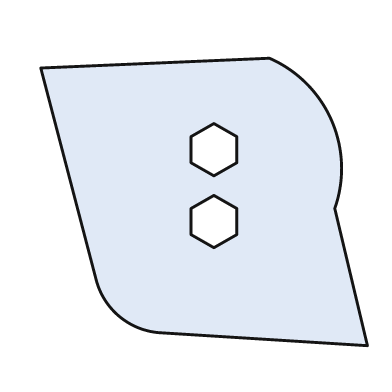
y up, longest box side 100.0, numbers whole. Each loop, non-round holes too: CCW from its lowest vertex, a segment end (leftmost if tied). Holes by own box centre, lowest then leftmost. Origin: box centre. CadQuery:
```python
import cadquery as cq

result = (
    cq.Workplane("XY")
    .moveTo(50.0, -44.0)
    .lineTo(40.0, -2.0)
    .threePointArc((39.0, 25.0), (20.0, 44.0))
    .lineTo(-50.0, 41.0)
    .lineTo(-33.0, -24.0)
    .threePointArc((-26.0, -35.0), (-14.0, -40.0))
    .close()
    .moveTo(3.0, -14.0)
    .lineTo(10.0, -10.0)
    .lineTo(10.0, -2.0)
    .lineTo(3.0, 2.0)
    .lineTo(-4.0, -2.0)
    .lineTo(-4.0, -10.0)
    .close()
    .moveTo(3.0, 8.0)
    .lineTo(10.0, 12.0)
    .lineTo(10.0, 20.0)
    .lineTo(3.0, 24.0)
    .lineTo(-4.0, 20.0)
    .lineTo(-4.0, 12.0)
    .close()
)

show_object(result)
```